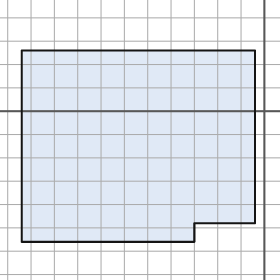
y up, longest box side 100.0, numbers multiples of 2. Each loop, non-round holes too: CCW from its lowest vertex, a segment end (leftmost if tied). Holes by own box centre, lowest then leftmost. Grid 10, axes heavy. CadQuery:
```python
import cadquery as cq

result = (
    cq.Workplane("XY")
    .moveTo(-104.0, -56.0)
    .lineTo(-30.0, -56.0)
    .lineTo(-30.0, -48.0)
    .lineTo(-4.0, -48.0)
    .lineTo(-4.0, 26.0)
    .lineTo(-104.0, 26.0)
    .close()
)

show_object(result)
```